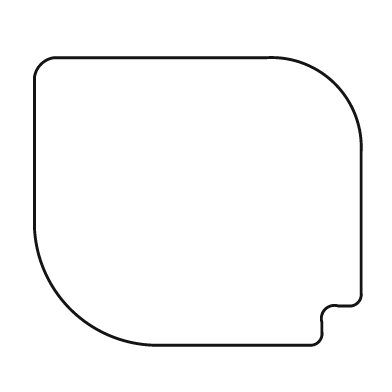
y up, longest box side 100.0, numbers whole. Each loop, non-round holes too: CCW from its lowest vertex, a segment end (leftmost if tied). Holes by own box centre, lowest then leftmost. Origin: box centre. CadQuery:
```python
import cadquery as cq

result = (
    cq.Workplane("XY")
    .moveTo(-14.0, -44.0)
    .lineTo(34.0, -44.0)
    .threePointArc((37.0, -43.0), (38.0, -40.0))
    .lineTo(38.0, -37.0)
    .threePointArc((39.0, -33.0), (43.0, -32.0))
    .lineTo(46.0, -32.0)
    .threePointArc((49.0, -31.0), (50.0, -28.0))
    .lineTo(50.0, 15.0)
    .threePointArc((42.0, 36.0), (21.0, 44.0))
    .lineTo(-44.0, 44.0)
    .threePointArc((-48.0, 42.0), (-50.0, 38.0))
    .lineTo(-50.0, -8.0)
    .threePointArc((-39.0, -33.0), (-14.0, -44.0))
    .close()
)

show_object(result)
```